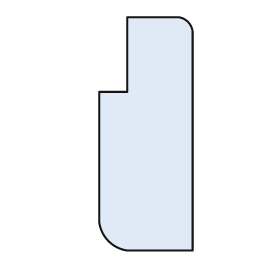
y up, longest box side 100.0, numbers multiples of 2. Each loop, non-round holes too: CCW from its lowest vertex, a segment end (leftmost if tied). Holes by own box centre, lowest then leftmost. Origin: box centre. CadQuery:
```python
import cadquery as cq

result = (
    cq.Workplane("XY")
    .moveTo(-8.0, -50.0)
    .lineTo(20.0, -50.0)
    .lineTo(20.0, 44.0)
    .threePointArc((18.0, 48.0), (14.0, 50.0))
    .lineTo(-8.0, 50.0)
    .lineTo(-8.0, 18.0)
    .lineTo(-20.0, 18.0)
    .lineTo(-20.0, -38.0)
    .threePointArc((-16.0, -46.0), (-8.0, -50.0))
    .close()
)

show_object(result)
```